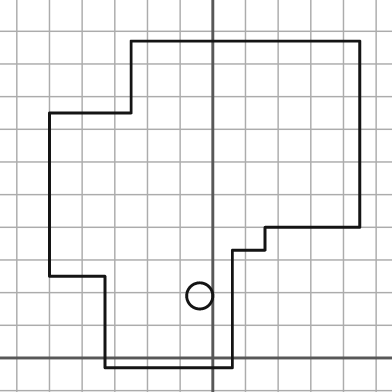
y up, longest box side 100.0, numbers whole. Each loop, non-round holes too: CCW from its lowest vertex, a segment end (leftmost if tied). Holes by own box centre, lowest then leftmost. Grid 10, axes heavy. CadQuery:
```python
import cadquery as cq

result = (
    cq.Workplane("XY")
    .moveTo(-33.0, -3.0)
    .lineTo(6.0, -3.0)
    .lineTo(6.0, 33.0)
    .lineTo(16.0, 33.0)
    .lineTo(16.0, 40.0)
    .lineTo(45.0, 40.0)
    .lineTo(45.0, 97.0)
    .lineTo(-25.0, 97.0)
    .lineTo(-25.0, 75.0)
    .lineTo(-50.0, 75.0)
    .lineTo(-50.0, 25.0)
    .lineTo(-33.0, 25.0)
    .close()
    .moveTo(-4.0, 19.0)
    .circle(4.0)
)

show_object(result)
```